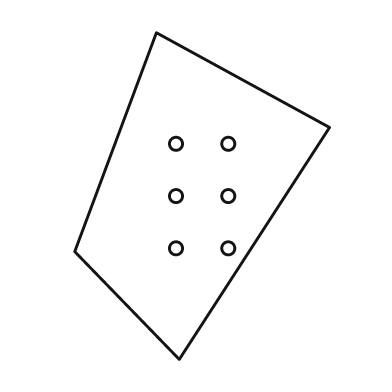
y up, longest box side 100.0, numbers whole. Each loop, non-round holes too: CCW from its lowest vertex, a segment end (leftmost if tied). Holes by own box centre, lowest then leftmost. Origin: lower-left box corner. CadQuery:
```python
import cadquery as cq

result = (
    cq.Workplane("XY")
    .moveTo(32.0, 0.0)
    .lineTo(78.0, 71.0)
    .lineTo(25.0, 100.0)
    .lineTo(0.0, 33.0)
    .close()
    .moveTo(31.0, 34.0)
    .circle(2.0)
    .moveTo(47.0, 34.0)
    .circle(2.0)
    .moveTo(31.0, 50.0)
    .circle(2.0)
    .moveTo(47.0, 50.0)
    .circle(2.0)
    .moveTo(31.0, 66.0)
    .circle(2.0)
    .moveTo(47.0, 66.0)
    .circle(2.0)
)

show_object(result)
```